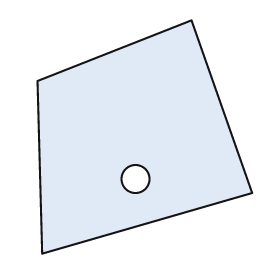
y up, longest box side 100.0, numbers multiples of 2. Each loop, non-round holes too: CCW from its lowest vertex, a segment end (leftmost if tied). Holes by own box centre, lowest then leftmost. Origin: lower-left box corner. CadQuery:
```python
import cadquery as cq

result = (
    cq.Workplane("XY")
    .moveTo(2.0, 0.0)
    .lineTo(92.0, 26.0)
    .lineTo(66.0, 100.0)
    .lineTo(0.0, 74.0)
    .close()
    .moveTo(42.0, 32.0)
    .circle(6.0)
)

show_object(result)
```